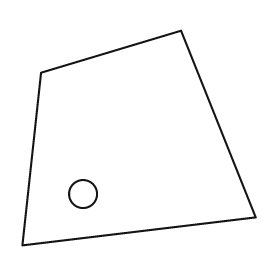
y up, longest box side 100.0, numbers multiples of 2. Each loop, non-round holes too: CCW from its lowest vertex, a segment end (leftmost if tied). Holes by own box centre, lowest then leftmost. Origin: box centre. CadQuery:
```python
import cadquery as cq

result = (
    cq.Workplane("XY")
    .moveTo(-50.0, -46.0)
    .lineTo(50.0, -34.0)
    .lineTo(18.0, 46.0)
    .lineTo(-42.0, 28.0)
    .close()
    .moveTo(-24.0, -24.0)
    .circle(6.0)
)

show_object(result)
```